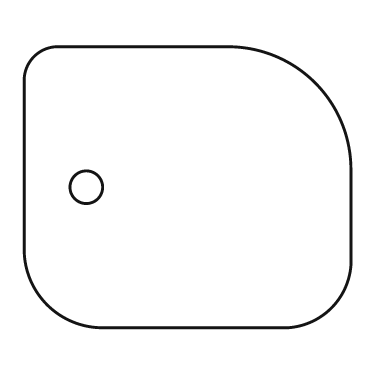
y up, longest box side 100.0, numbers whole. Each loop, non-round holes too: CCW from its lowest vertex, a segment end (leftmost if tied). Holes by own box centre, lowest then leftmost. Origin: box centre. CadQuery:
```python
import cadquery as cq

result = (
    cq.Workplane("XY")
    .moveTo(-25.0, -43.0)
    .lineTo(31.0, -43.0)
    .threePointArc((44.0, -37.0), (50.0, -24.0))
    .lineTo(50.0, 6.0)
    .threePointArc((39.0, 32.0), (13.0, 43.0))
    .lineTo(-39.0, 43.0)
    .threePointArc((-47.0, 40.0), (-50.0, 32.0))
    .lineTo(-50.0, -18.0)
    .threePointArc((-43.0, -36.0), (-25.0, -43.0))
    .close()
    .moveTo(-31.0, 0.0)
    .circle(5.0)
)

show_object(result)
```